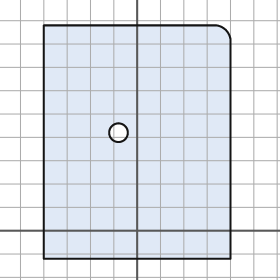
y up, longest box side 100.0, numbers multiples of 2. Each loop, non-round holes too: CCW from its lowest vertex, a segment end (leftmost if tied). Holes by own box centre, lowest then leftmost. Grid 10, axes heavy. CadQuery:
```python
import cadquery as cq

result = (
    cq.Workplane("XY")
    .moveTo(-40.0, -12.0)
    .lineTo(40.0, -12.0)
    .lineTo(40.0, 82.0)
    .threePointArc((38.0, 86.0), (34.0, 88.0))
    .lineTo(-40.0, 88.0)
    .close()
    .moveTo(-8.0, 42.0)
    .circle(4.0)
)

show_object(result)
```